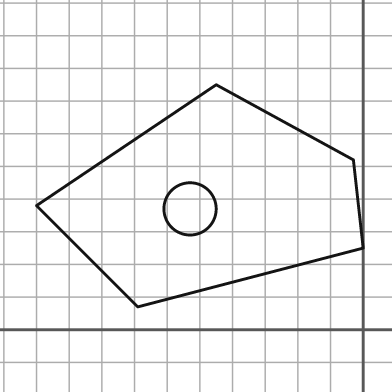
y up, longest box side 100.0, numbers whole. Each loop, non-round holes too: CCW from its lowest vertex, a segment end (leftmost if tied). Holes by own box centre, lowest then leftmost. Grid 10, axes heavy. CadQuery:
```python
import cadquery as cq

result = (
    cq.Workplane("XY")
    .moveTo(-69.0, 7.0)
    .lineTo(0.0, 25.0)
    .lineTo(-3.0, 52.0)
    .lineTo(-45.0, 75.0)
    .lineTo(-100.0, 38.0)
    .close()
    .moveTo(-53.0, 37.0)
    .circle(8.0)
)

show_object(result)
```